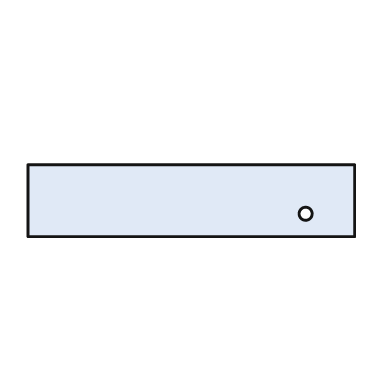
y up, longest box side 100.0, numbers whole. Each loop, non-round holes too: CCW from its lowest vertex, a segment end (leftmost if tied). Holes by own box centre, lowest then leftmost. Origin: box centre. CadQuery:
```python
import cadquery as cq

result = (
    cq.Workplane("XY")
    .moveTo(-50.0, -11.0)
    .lineTo(50.0, -11.0)
    .lineTo(50.0, 11.0)
    .lineTo(-50.0, 11.0)
    .close()
    .moveTo(35.0, -4.0)
    .circle(2.0)
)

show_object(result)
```